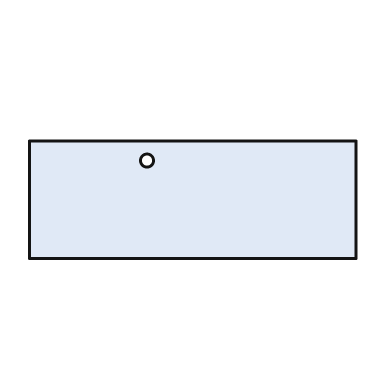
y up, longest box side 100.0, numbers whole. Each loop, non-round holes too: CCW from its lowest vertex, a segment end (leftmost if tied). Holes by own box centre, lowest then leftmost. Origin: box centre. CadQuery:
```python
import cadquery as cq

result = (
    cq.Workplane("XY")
    .moveTo(-50.0, -18.0)
    .lineTo(50.0, -18.0)
    .lineTo(50.0, 18.0)
    .lineTo(-50.0, 18.0)
    .close()
    .moveTo(-14.0, 12.0)
    .circle(2.0)
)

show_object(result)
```